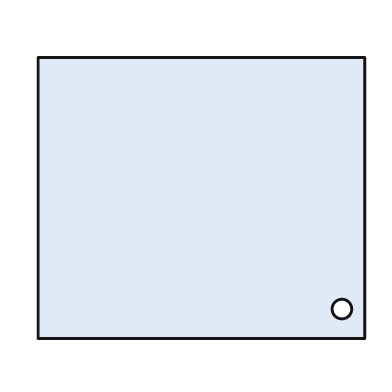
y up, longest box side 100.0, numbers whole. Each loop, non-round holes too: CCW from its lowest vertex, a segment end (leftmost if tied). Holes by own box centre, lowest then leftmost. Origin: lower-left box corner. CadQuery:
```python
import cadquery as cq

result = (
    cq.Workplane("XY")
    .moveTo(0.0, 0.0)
    .lineTo(100.0, 0.0)
    .lineTo(100.0, 86.0)
    .lineTo(0.0, 86.0)
    .close()
    .moveTo(93.0, 9.0)
    .circle(3.0)
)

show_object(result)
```